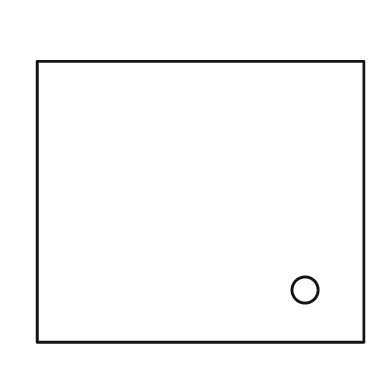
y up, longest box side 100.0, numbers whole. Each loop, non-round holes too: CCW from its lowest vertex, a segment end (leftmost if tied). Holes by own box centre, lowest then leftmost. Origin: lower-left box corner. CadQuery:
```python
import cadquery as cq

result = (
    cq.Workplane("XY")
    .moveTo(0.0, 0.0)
    .lineTo(100.0, 0.0)
    .lineTo(100.0, 86.0)
    .lineTo(0.0, 86.0)
    .close()
    .moveTo(82.0, 16.0)
    .circle(4.0)
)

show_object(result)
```